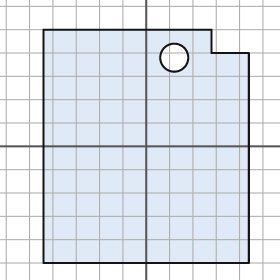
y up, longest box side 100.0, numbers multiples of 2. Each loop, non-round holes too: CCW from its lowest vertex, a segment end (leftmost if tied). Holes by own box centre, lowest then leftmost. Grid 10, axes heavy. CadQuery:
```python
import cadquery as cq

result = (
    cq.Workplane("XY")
    .moveTo(-44.0, -50.0)
    .lineTo(44.0, -50.0)
    .lineTo(44.0, 40.0)
    .lineTo(28.0, 40.0)
    .lineTo(28.0, 50.0)
    .lineTo(-44.0, 50.0)
    .close()
    .moveTo(12.0, 38.0)
    .circle(6.0)
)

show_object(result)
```